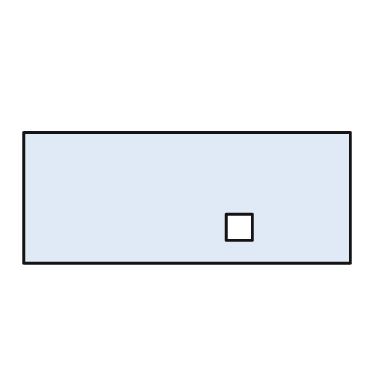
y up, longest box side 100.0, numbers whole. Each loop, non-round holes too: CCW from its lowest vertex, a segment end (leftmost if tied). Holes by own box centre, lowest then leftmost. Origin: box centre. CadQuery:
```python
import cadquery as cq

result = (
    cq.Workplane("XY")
    .moveTo(-50.0, -20.0)
    .lineTo(50.0, -20.0)
    .lineTo(50.0, 20.0)
    .lineTo(-50.0, 20.0)
    .close()
    .moveTo(12.0, -13.0)
    .lineTo(20.0, -13.0)
    .lineTo(20.0, -5.0)
    .lineTo(12.0, -5.0)
    .close()
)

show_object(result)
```